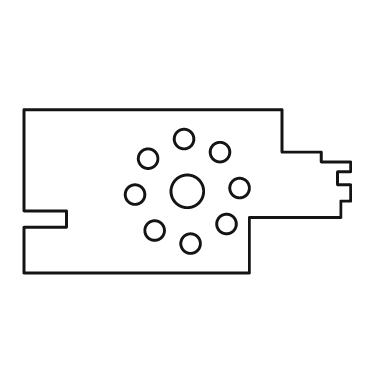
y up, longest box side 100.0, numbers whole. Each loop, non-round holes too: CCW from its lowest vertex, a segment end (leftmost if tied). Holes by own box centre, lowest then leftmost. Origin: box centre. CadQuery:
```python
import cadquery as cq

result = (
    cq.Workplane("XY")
    .moveTo(-50.0, -25.0)
    .lineTo(19.0, -25.0)
    .lineTo(19.0, -8.0)
    .lineTo(47.0, -8.0)
    .lineTo(47.0, -3.0)
    .lineTo(50.0, -3.0)
    .lineTo(50.0, 2.0)
    .lineTo(46.0, 2.0)
    .lineTo(46.0, 6.0)
    .lineTo(50.0, 6.0)
    .lineTo(50.0, 9.0)
    .lineTo(41.0, 9.0)
    .lineTo(41.0, 12.0)
    .lineTo(29.0, 12.0)
    .lineTo(29.0, 25.0)
    .lineTo(-50.0, 25.0)
    .lineTo(-50.0, -6.0)
    .lineTo(-37.0, -6.0)
    .lineTo(-37.0, -11.0)
    .lineTo(-50.0, -11.0)
    .close()
    .moveTo(1.0, -16.0)
    .circle(3.0)
    .moveTo(-10.0, -12.0)
    .circle(3.0)
    .moveTo(12.0, -10.0)
    .circle(3.0)
    .moveTo(-16.0, -1.0)
    .circle(3.0)
    .moveTo(0.0, 0.0)
    .circle(5.0)
    .moveTo(16.0, 1.0)
    .circle(3.0)
    .moveTo(-12.0, 10.0)
    .circle(3.0)
    .moveTo(10.0, 12.0)
    .circle(3.0)
    .moveTo(-1.0, 16.0)
    .circle(3.0)
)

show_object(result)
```